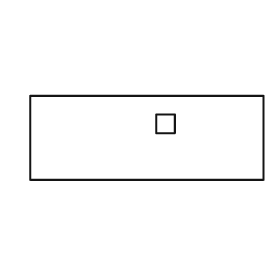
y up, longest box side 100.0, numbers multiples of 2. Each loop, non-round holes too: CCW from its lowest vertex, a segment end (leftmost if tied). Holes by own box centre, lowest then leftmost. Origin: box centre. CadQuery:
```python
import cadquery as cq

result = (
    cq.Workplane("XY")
    .moveTo(-50.0, -18.0)
    .lineTo(50.0, -18.0)
    .lineTo(50.0, 18.0)
    .lineTo(-50.0, 18.0)
    .close()
    .moveTo(4.0, 2.0)
    .lineTo(12.0, 2.0)
    .lineTo(12.0, 10.0)
    .lineTo(4.0, 10.0)
    .close()
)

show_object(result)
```